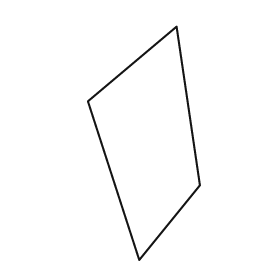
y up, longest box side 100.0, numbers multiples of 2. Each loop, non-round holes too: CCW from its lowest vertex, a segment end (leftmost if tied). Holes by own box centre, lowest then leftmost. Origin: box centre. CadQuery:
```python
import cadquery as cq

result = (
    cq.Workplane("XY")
    .moveTo(-2.0, -50.0)
    .lineTo(24.0, -18.0)
    .lineTo(14.0, 50.0)
    .lineTo(-24.0, 18.0)
    .close()
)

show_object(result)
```